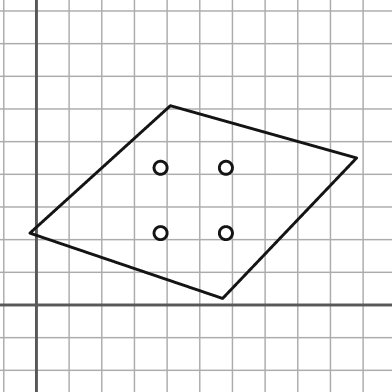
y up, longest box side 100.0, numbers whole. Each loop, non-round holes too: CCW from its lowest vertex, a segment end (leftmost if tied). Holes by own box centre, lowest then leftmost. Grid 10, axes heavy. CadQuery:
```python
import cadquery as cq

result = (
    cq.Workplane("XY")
    .moveTo(57.0, 2.0)
    .lineTo(98.0, 45.0)
    .lineTo(41.0, 61.0)
    .lineTo(-2.0, 22.0)
    .close()
    .moveTo(38.0, 22.0)
    .circle(2.0)
    .moveTo(58.0, 22.0)
    .circle(2.0)
    .moveTo(38.0, 42.0)
    .circle(2.0)
    .moveTo(58.0, 42.0)
    .circle(2.0)
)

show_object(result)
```